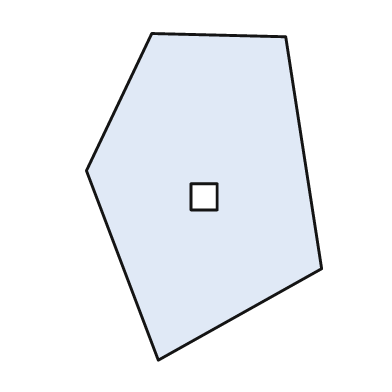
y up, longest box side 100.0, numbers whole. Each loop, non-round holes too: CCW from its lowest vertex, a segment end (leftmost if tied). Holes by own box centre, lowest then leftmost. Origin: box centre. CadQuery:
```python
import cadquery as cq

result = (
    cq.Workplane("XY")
    .moveTo(-14.0, -50.0)
    .lineTo(36.0, -22.0)
    .lineTo(25.0, 49.0)
    .lineTo(-16.0, 50.0)
    .lineTo(-36.0, 8.0)
    .close()
    .moveTo(-4.0, -4.0)
    .lineTo(4.0, -4.0)
    .lineTo(4.0, 4.0)
    .lineTo(-4.0, 4.0)
    .close()
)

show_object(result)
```